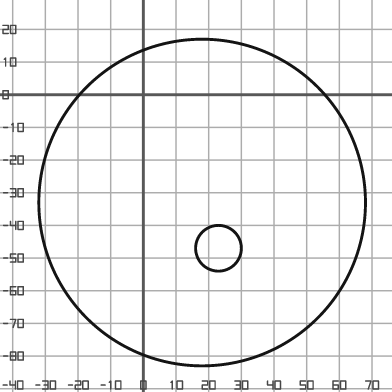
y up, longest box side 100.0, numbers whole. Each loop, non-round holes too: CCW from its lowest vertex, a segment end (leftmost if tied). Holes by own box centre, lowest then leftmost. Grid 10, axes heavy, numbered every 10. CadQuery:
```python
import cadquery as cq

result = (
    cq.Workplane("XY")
    .moveTo(18.0, -33.0)
    .circle(50.0)
    .moveTo(23.0, -47.0)
    .circle(7.0)
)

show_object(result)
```